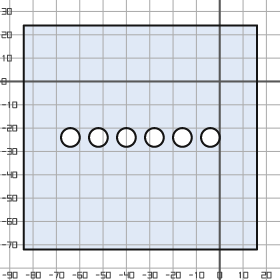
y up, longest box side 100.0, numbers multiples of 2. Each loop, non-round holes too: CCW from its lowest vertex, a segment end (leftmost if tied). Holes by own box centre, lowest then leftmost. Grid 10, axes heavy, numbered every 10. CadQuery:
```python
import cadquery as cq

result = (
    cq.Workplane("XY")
    .moveTo(-84.0, -72.0)
    .lineTo(16.0, -72.0)
    .lineTo(16.0, 24.0)
    .lineTo(-84.0, 24.0)
    .close()
    .moveTo(-64.0, -24.0)
    .circle(4.0)
    .moveTo(-52.0, -24.0)
    .circle(4.0)
    .moveTo(-40.0, -24.0)
    .circle(4.0)
    .moveTo(-28.0, -24.0)
    .circle(4.0)
    .moveTo(-16.0, -24.0)
    .circle(4.0)
    .moveTo(-4.0, -24.0)
    .circle(4.0)
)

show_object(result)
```